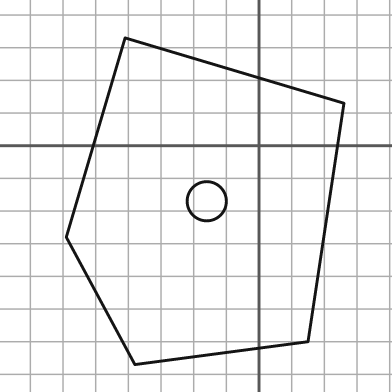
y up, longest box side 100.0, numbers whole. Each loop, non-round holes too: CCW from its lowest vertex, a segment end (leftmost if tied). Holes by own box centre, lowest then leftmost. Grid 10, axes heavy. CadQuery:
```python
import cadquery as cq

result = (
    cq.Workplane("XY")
    .moveTo(-38.0, -67.0)
    .lineTo(15.0, -60.0)
    .lineTo(26.0, 13.0)
    .lineTo(-41.0, 33.0)
    .lineTo(-59.0, -28.0)
    .close()
    .moveTo(-16.0, -17.0)
    .circle(6.0)
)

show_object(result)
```